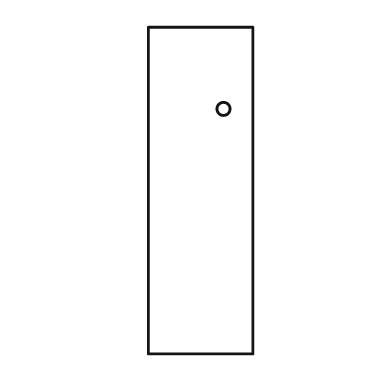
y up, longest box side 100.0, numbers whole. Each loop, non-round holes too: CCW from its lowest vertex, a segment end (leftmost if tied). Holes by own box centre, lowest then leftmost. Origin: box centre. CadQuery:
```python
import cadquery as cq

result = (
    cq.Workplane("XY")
    .moveTo(-16.0, -50.0)
    .lineTo(16.0, -50.0)
    .lineTo(16.0, 50.0)
    .lineTo(-16.0, 50.0)
    .close()
    .moveTo(7.0, 25.0)
    .circle(2.0)
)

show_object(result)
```